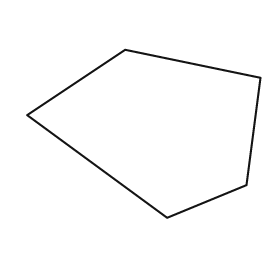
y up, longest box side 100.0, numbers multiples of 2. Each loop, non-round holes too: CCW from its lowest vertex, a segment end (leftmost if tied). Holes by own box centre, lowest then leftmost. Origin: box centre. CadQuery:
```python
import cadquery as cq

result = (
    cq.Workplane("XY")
    .moveTo(10.0, -36.0)
    .lineTo(44.0, -22.0)
    .lineTo(50.0, 24.0)
    .lineTo(-8.0, 36.0)
    .lineTo(-50.0, 8.0)
    .close()
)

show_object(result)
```